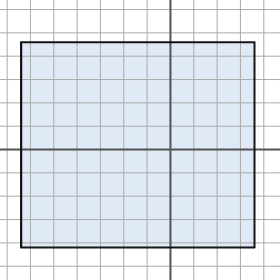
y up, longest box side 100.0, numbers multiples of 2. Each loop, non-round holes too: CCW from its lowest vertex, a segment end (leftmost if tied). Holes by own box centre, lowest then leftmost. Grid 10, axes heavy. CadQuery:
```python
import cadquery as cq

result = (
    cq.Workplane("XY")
    .moveTo(-64.0, -42.0)
    .lineTo(36.0, -42.0)
    .lineTo(36.0, 46.0)
    .lineTo(-64.0, 46.0)
    .close()
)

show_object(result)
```